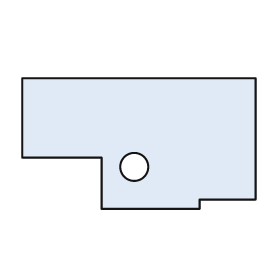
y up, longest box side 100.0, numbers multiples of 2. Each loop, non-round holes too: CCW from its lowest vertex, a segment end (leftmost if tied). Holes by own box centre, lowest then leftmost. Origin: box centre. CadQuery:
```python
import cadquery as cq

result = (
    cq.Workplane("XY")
    .moveTo(-16.0, -28.0)
    .lineTo(26.0, -28.0)
    .lineTo(26.0, -24.0)
    .lineTo(50.0, -24.0)
    .lineTo(50.0, 28.0)
    .lineTo(-50.0, 28.0)
    .lineTo(-50.0, -6.0)
    .lineTo(-16.0, -6.0)
    .close()
    .moveTo(-2.0, -10.0)
    .circle(6.0)
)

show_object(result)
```